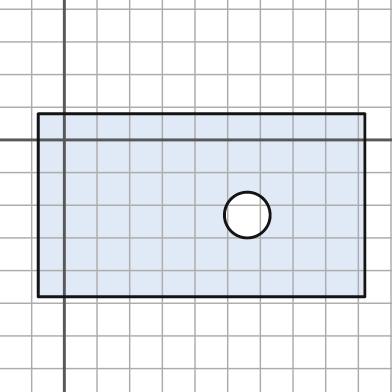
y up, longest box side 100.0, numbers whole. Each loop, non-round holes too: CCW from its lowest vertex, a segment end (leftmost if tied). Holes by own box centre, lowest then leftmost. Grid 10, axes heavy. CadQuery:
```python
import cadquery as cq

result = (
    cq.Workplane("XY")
    .moveTo(-8.0, -48.0)
    .lineTo(92.0, -48.0)
    .lineTo(92.0, 8.0)
    .lineTo(-8.0, 8.0)
    .close()
    .moveTo(56.0, -23.0)
    .circle(7.0)
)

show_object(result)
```